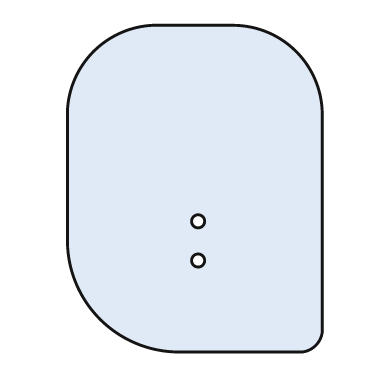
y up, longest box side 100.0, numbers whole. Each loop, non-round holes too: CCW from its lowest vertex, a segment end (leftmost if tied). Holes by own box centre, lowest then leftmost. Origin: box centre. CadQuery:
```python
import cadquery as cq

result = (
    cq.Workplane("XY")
    .moveTo(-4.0, -50.0)
    .lineTo(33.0, -50.0)
    .threePointArc((37.0, -48.0), (39.0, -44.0))
    .lineTo(39.0, 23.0)
    .threePointArc((31.0, 42.0), (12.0, 50.0))
    .lineTo(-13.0, 50.0)
    .threePointArc((-31.0, 42.0), (-39.0, 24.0))
    .lineTo(-39.0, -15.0)
    .threePointArc((-29.0, -40.0), (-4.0, -50.0))
    .close()
    .moveTo(1.0, -22.0)
    .circle(2.0)
    .moveTo(1.0, -10.0)
    .circle(2.0)
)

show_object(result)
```